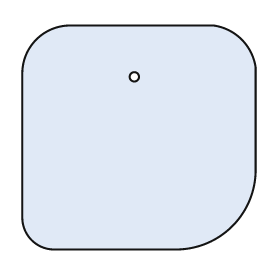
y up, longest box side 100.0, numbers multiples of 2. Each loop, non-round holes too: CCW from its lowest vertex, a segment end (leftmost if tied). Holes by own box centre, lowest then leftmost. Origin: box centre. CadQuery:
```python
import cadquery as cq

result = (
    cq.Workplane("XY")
    .moveTo(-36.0, -48.0)
    .lineTo(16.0, -48.0)
    .threePointArc((40.0, -38.0), (50.0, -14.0))
    .lineTo(50.0, 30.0)
    .threePointArc((44.0, 42.0), (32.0, 48.0))
    .lineTo(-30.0, 48.0)
    .threePointArc((-44.0, 42.0), (-50.0, 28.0))
    .lineTo(-50.0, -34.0)
    .threePointArc((-46.0, -44.0), (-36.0, -48.0))
    .close()
    .moveTo(-2.0, 26.0)
    .circle(2.0)
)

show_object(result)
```